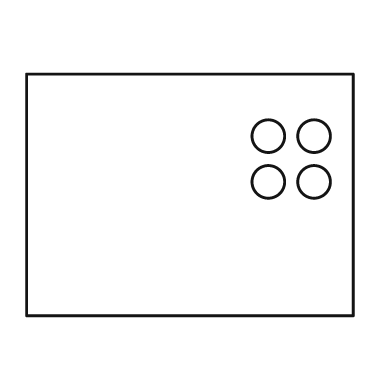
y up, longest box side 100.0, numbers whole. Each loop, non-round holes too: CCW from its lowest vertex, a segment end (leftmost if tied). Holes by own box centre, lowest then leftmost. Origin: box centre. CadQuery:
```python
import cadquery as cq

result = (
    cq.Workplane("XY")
    .moveTo(-50.0, -37.0)
    .lineTo(50.0, -37.0)
    .lineTo(50.0, 37.0)
    .lineTo(-50.0, 37.0)
    .close()
    .moveTo(24.0, 4.0)
    .circle(5.0)
    .moveTo(38.0, 4.0)
    .circle(5.0)
    .moveTo(24.0, 18.0)
    .circle(5.0)
    .moveTo(38.0, 18.0)
    .circle(5.0)
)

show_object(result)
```